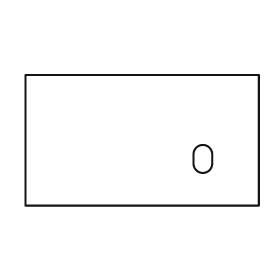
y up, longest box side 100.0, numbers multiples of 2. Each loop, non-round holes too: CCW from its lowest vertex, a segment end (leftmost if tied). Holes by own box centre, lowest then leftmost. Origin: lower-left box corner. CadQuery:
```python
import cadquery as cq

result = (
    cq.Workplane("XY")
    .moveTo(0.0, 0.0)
    .lineTo(100.0, 0.0)
    .lineTo(100.0, 56.0)
    .lineTo(0.0, 56.0)
    .close()
    .moveTo(72.0, 18.0)
    .threePointArc((76.0, 14.0), (80.0, 18.0))
    .lineTo(80.0, 22.0)
    .threePointArc((76.0, 26.0), (72.0, 22.0))
    .close()
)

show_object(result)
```